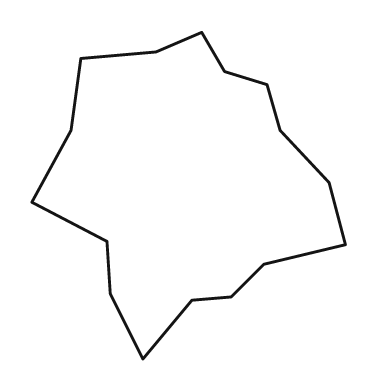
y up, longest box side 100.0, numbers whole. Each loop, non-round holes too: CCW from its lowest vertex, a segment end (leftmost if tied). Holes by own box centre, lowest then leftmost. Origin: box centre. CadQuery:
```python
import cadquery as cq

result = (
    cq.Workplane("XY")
    .moveTo(-14.0, -50.0)
    .lineTo(1.0, -32.0)
    .lineTo(13.0, -31.0)
    .lineTo(23.0, -21.0)
    .lineTo(48.0, -15.0)
    .lineTo(43.0, 4.0)
    .lineTo(28.0, 20.0)
    .lineTo(24.0, 34.0)
    .lineTo(11.0, 38.0)
    .lineTo(4.0, 50.0)
    .lineTo(-10.0, 44.0)
    .lineTo(-33.0, 42.0)
    .lineTo(-36.0, 20.0)
    .lineTo(-48.0, -2.0)
    .lineTo(-25.0, -14.0)
    .lineTo(-24.0, -30.0)
    .close()
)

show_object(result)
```